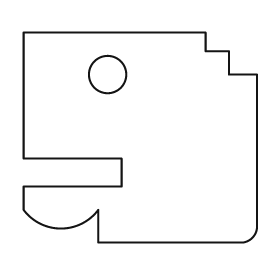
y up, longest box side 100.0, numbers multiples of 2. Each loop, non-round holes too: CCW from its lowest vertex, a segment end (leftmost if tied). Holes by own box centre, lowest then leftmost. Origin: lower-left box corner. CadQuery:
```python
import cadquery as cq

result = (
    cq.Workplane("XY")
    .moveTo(32.0, 0.0)
    .lineTo(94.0, 0.0)
    .threePointArc((98.0, 2.0), (100.0, 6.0))
    .lineTo(100.0, 72.0)
    .lineTo(88.0, 72.0)
    .lineTo(88.0, 82.0)
    .lineTo(78.0, 82.0)
    .lineTo(78.0, 90.0)
    .lineTo(0.0, 90.0)
    .lineTo(0.0, 36.0)
    .lineTo(42.0, 36.0)
    .lineTo(42.0, 24.0)
    .lineTo(0.0, 24.0)
    .lineTo(0.0, 14.0)
    .threePointArc((16.0, 6.0), (32.0, 14.0))
    .close()
    .moveTo(36.0, 72.0)
    .circle(8.0)
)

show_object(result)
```